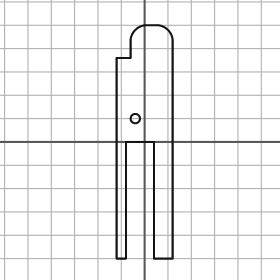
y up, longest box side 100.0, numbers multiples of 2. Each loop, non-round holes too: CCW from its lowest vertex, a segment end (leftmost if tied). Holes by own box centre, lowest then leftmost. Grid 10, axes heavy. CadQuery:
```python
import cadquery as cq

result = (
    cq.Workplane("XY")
    .moveTo(-12.0, -50.0)
    .lineTo(-8.0, -50.0)
    .lineTo(-8.0, 0.0)
    .lineTo(4.0, 0.0)
    .lineTo(4.0, -50.0)
    .lineTo(12.0, -50.0)
    .lineTo(12.0, 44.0)
    .threePointArc((10.0, 48.0), (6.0, 50.0))
    .lineTo(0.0, 50.0)
    .threePointArc((-4.0, 48.0), (-6.0, 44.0))
    .lineTo(-6.0, 36.0)
    .lineTo(-12.0, 36.0)
    .close()
    .moveTo(-4.0, 10.0)
    .circle(2.0)
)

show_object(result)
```